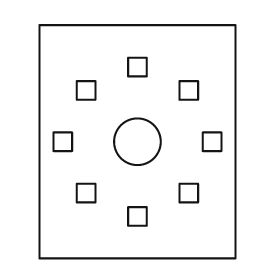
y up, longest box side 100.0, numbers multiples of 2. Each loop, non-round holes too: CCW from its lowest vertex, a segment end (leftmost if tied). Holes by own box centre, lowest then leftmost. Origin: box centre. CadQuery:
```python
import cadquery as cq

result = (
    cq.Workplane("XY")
    .moveTo(-42.0, -50.0)
    .lineTo(42.0, -50.0)
    .lineTo(42.0, 50.0)
    .lineTo(-42.0, 50.0)
    .close()
    .moveTo(-4.0, -36.0)
    .lineTo(4.0, -36.0)
    .lineTo(4.0, -28.0)
    .lineTo(-4.0, -28.0)
    .close()
    .moveTo(-26.0, -26.0)
    .lineTo(-18.0, -26.0)
    .lineTo(-18.0, -18.0)
    .lineTo(-26.0, -18.0)
    .close()
    .moveTo(18.0, -26.0)
    .lineTo(26.0, -26.0)
    .lineTo(26.0, -18.0)
    .lineTo(18.0, -18.0)
    .close()
    .moveTo(-36.0, -4.0)
    .lineTo(-28.0, -4.0)
    .lineTo(-28.0, 4.0)
    .lineTo(-36.0, 4.0)
    .close()
    .moveTo(0.0, 0.0)
    .circle(10.0)
    .moveTo(28.0, -4.0)
    .lineTo(36.0, -4.0)
    .lineTo(36.0, 4.0)
    .lineTo(28.0, 4.0)
    .close()
    .moveTo(-26.0, 18.0)
    .lineTo(-18.0, 18.0)
    .lineTo(-18.0, 26.0)
    .lineTo(-26.0, 26.0)
    .close()
    .moveTo(18.0, 18.0)
    .lineTo(26.0, 18.0)
    .lineTo(26.0, 26.0)
    .lineTo(18.0, 26.0)
    .close()
    .moveTo(-4.0, 28.0)
    .lineTo(4.0, 28.0)
    .lineTo(4.0, 36.0)
    .lineTo(-4.0, 36.0)
    .close()
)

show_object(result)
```